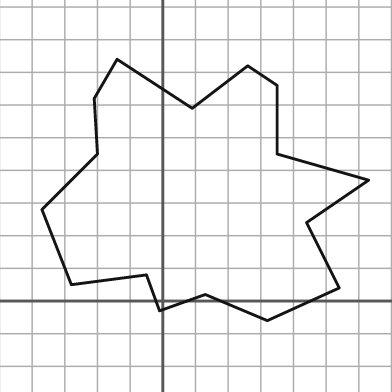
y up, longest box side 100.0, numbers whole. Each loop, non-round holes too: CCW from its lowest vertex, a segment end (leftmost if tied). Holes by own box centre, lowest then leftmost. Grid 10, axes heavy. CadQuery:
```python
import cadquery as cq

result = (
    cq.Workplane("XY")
    .moveTo(32.0, -6.0)
    .lineTo(54.0, 4.0)
    .lineTo(44.0, 24.0)
    .lineTo(63.0, 37.0)
    .lineTo(35.0, 45.0)
    .lineTo(35.0, 66.0)
    .lineTo(26.0, 72.0)
    .lineTo(9.0, 59.0)
    .lineTo(-14.0, 74.0)
    .lineTo(-21.0, 62.0)
    .lineTo(-20.0, 45.0)
    .lineTo(-37.0, 28.0)
    .lineTo(-28.0, 5.0)
    .lineTo(-5.0, 8.0)
    .lineTo(-1.0, -3.0)
    .lineTo(13.0, 2.0)
    .close()
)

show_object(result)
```